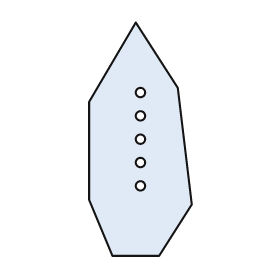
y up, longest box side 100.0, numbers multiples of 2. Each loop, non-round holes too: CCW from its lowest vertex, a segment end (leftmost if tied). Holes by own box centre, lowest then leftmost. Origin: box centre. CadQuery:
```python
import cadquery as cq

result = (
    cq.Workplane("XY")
    .moveTo(-12.0, -50.0)
    .lineTo(8.0, -50.0)
    .lineTo(22.0, -28.0)
    .lineTo(16.0, 22.0)
    .lineTo(-2.0, 50.0)
    .lineTo(-22.0, 16.0)
    .lineTo(-22.0, -26.0)
    .close()
    .moveTo(0.0, -20.0)
    .circle(2.0)
    .moveTo(0.0, -10.0)
    .circle(2.0)
    .moveTo(0.0, 0.0)
    .circle(2.0)
    .moveTo(0.0, 10.0)
    .circle(2.0)
    .moveTo(0.0, 20.0)
    .circle(2.0)
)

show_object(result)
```